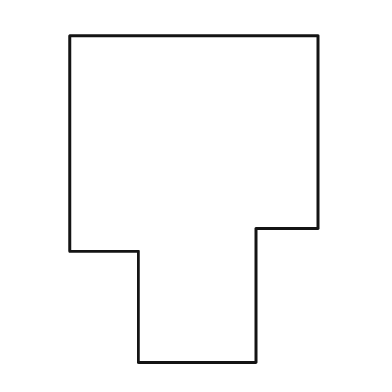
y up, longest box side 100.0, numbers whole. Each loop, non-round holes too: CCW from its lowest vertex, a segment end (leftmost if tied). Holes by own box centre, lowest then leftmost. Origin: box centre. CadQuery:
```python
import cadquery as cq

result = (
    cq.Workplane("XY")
    .moveTo(-17.0, -50.0)
    .lineTo(19.0, -50.0)
    .lineTo(19.0, -9.0)
    .lineTo(38.0, -9.0)
    .lineTo(38.0, 50.0)
    .lineTo(-38.0, 50.0)
    .lineTo(-38.0, -16.0)
    .lineTo(-17.0, -16.0)
    .close()
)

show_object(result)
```